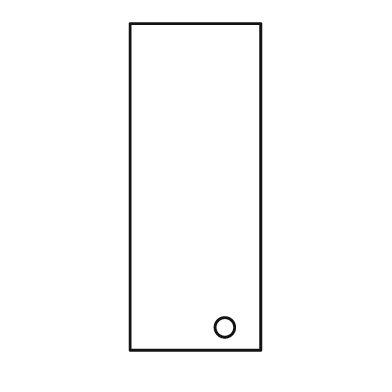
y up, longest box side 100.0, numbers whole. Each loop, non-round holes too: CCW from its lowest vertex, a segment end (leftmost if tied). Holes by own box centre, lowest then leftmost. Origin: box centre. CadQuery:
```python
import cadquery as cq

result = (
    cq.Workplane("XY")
    .moveTo(-20.0, -50.0)
    .lineTo(20.0, -50.0)
    .lineTo(20.0, 50.0)
    .lineTo(-20.0, 50.0)
    .close()
    .moveTo(9.0, -43.0)
    .circle(3.0)
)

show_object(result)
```